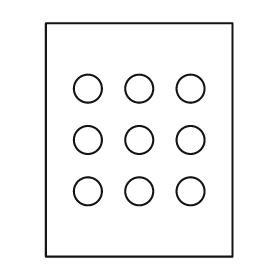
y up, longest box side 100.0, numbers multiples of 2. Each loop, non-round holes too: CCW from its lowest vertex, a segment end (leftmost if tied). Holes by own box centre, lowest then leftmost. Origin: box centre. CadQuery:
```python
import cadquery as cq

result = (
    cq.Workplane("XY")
    .moveTo(-40.0, -50.0)
    .lineTo(40.0, -50.0)
    .lineTo(40.0, 50.0)
    .lineTo(-40.0, 50.0)
    .close()
    .moveTo(-22.0, -22.0)
    .circle(6.0)
    .moveTo(0.0, -22.0)
    .circle(6.0)
    .moveTo(22.0, -22.0)
    .circle(6.0)
    .moveTo(-22.0, 0.0)
    .circle(6.0)
    .moveTo(0.0, 0.0)
    .circle(6.0)
    .moveTo(22.0, 0.0)
    .circle(6.0)
    .moveTo(-22.0, 22.0)
    .circle(6.0)
    .moveTo(0.0, 22.0)
    .circle(6.0)
    .moveTo(22.0, 22.0)
    .circle(6.0)
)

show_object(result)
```